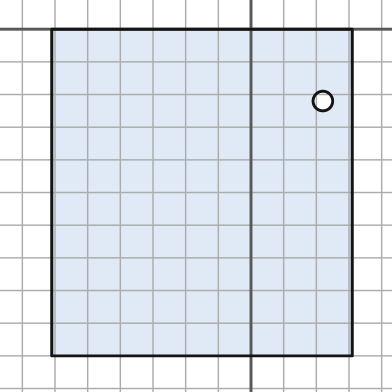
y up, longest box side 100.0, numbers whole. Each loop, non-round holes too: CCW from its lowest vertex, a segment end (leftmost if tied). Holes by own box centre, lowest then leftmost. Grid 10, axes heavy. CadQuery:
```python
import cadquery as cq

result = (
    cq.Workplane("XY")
    .moveTo(-61.0, -100.0)
    .lineTo(31.0, -100.0)
    .lineTo(31.0, 0.0)
    .lineTo(-61.0, 0.0)
    .close()
    .moveTo(22.0, -22.0)
    .circle(3.0)
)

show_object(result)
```